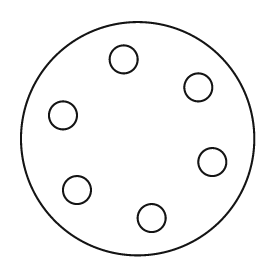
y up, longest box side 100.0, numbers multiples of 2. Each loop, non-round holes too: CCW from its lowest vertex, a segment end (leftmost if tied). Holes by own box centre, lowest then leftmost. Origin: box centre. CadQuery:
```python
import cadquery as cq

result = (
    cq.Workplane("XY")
    .moveTo(0.0, 0.0)
    .circle(50.0)
    .moveTo(6.0, -34.0)
    .circle(6.0)
    .moveTo(-26.0, -22.0)
    .circle(6.0)
    .moveTo(32.0, -10.0)
    .circle(6.0)
    .moveTo(-32.0, 10.0)
    .circle(6.0)
    .moveTo(26.0, 22.0)
    .circle(6.0)
    .moveTo(-6.0, 34.0)
    .circle(6.0)
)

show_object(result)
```